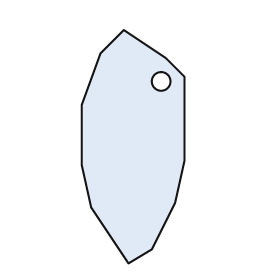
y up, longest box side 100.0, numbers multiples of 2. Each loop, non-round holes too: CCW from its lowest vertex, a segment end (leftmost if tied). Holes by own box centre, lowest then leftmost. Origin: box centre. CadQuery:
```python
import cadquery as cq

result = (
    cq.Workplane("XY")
    .moveTo(-2.0, -50.0)
    .lineTo(8.0, -44.0)
    .lineTo(18.0, -24.0)
    .lineTo(22.0, -6.0)
    .lineTo(22.0, 30.0)
    .lineTo(14.0, 38.0)
    .lineTo(-4.0, 50.0)
    .lineTo(-14.0, 40.0)
    .lineTo(-22.0, 18.0)
    .lineTo(-22.0, -8.0)
    .lineTo(-18.0, -26.0)
    .close()
    .moveTo(12.0, 28.0)
    .circle(4.0)
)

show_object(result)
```